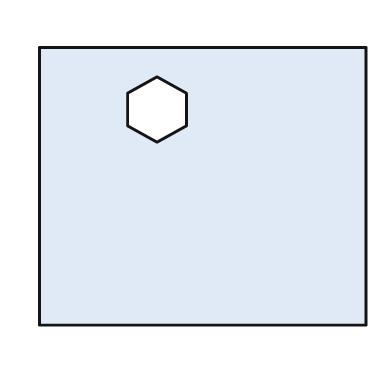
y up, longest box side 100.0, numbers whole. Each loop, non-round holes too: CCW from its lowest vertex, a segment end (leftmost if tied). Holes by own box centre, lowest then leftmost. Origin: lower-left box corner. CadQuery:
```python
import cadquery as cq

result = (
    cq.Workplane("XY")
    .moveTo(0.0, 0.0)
    .lineTo(100.0, 0.0)
    .lineTo(100.0, 85.0)
    .lineTo(0.0, 85.0)
    .close()
    .moveTo(36.0, 56.0)
    .lineTo(45.0, 61.0)
    .lineTo(45.0, 71.0)
    .lineTo(36.0, 76.0)
    .lineTo(27.0, 71.0)
    .lineTo(27.0, 61.0)
    .close()
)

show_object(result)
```